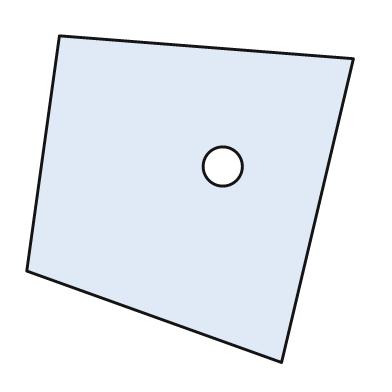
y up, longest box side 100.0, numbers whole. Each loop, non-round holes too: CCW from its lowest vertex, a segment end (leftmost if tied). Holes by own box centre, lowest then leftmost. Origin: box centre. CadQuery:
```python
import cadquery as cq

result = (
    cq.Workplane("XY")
    .moveTo(28.0, -50.0)
    .lineTo(50.0, 43.0)
    .lineTo(-40.0, 50.0)
    .lineTo(-50.0, -22.0)
    .close()
    .moveTo(10.0, 10.0)
    .circle(6.0)
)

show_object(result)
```